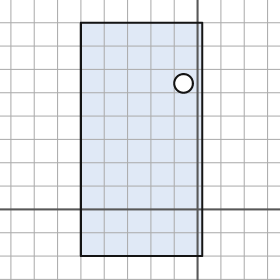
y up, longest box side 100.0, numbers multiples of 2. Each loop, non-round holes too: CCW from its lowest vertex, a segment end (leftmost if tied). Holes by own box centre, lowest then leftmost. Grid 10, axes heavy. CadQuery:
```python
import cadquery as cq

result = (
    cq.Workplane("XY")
    .moveTo(-50.0, -20.0)
    .lineTo(2.0, -20.0)
    .lineTo(2.0, 80.0)
    .lineTo(-50.0, 80.0)
    .close()
    .moveTo(-6.0, 54.0)
    .circle(4.0)
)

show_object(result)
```